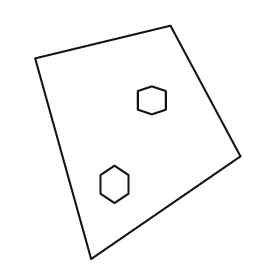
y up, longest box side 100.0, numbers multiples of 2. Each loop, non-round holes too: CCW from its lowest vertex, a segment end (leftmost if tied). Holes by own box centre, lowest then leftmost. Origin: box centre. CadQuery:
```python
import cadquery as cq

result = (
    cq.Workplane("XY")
    .moveTo(-20.0, -50.0)
    .lineTo(44.0, -6.0)
    .lineTo(14.0, 50.0)
    .lineTo(-44.0, 36.0)
    .close()
    .moveTo(-10.0, -26.0)
    .lineTo(-4.0, -22.0)
    .lineTo(-4.0, -14.0)
    .lineTo(-10.0, -10.0)
    .lineTo(-16.0, -14.0)
    .lineTo(-16.0, -22.0)
    .close()
    .moveTo(6.0, 12.0)
    .lineTo(12.0, 14.0)
    .lineTo(12.0, 22.0)
    .lineTo(6.0, 24.0)
    .lineTo(0.0, 22.0)
    .lineTo(0.0, 14.0)
    .close()
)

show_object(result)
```